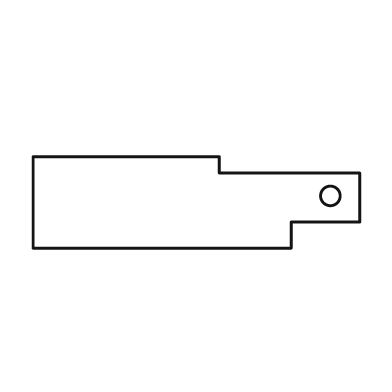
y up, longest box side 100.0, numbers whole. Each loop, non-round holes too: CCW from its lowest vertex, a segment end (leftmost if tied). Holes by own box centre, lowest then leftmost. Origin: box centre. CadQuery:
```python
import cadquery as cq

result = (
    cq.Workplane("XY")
    .moveTo(-50.0, -14.0)
    .lineTo(29.0, -14.0)
    .lineTo(29.0, -6.0)
    .lineTo(50.0, -6.0)
    .lineTo(50.0, 9.0)
    .lineTo(7.0, 9.0)
    .lineTo(7.0, 14.0)
    .lineTo(-50.0, 14.0)
    .close()
    .moveTo(41.0, 2.0)
    .circle(3.0)
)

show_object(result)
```